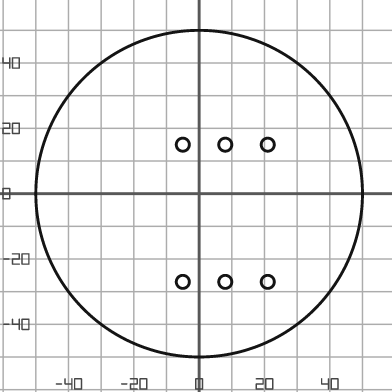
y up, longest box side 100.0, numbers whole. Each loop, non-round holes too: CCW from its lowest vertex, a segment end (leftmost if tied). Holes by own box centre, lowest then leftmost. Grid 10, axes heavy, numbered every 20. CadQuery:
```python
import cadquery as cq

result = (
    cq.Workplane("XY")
    .moveTo(0.0, 0.0)
    .circle(50.0)
    .moveTo(-5.0, -27.0)
    .circle(2.0)
    .moveTo(8.0, -27.0)
    .circle(2.0)
    .moveTo(21.0, -27.0)
    .circle(2.0)
    .moveTo(-5.0, 15.0)
    .circle(2.0)
    .moveTo(8.0, 15.0)
    .circle(2.0)
    .moveTo(21.0, 15.0)
    .circle(2.0)
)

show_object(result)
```